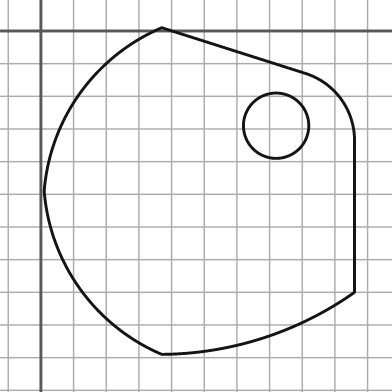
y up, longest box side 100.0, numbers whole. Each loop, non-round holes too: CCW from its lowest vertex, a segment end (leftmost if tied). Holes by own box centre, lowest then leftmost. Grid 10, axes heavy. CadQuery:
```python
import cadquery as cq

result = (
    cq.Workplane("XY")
    .moveTo(37.0, -99.0)
    .threePointArc((68.0, -94.0), (96.0, -80.0))
    .lineTo(96.0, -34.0)
    .threePointArc((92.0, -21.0), (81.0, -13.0))
    .lineTo(37.0, 1.0)
    .threePointArc((12.0, -19.0), (1.0, -49.0))
    .threePointArc((12.0, -79.0), (37.0, -99.0))
    .close()
    .moveTo(72.0, -29.0)
    .circle(10.0)
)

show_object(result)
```